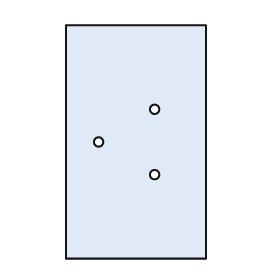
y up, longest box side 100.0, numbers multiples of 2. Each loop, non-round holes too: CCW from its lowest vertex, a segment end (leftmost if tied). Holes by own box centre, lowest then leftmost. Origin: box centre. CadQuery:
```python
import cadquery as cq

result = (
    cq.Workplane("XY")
    .moveTo(-30.0, -50.0)
    .lineTo(30.0, -50.0)
    .lineTo(30.0, 50.0)
    .lineTo(-30.0, 50.0)
    .close()
    .moveTo(8.0, -14.0)
    .circle(2.0)
    .moveTo(-16.0, 0.0)
    .circle(2.0)
    .moveTo(8.0, 14.0)
    .circle(2.0)
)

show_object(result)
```